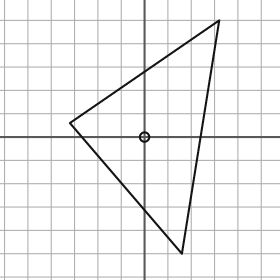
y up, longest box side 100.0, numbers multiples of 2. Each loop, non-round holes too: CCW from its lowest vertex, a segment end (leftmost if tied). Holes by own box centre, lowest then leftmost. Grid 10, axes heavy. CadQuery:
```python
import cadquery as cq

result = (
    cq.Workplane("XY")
    .moveTo(16.0, -50.0)
    .lineTo(32.0, 50.0)
    .lineTo(-32.0, 6.0)
    .close()
    .moveTo(0.0, 0.0)
    .circle(2.0)
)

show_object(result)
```